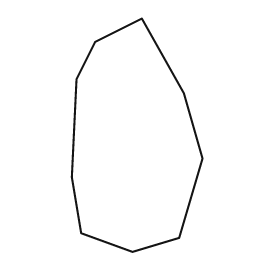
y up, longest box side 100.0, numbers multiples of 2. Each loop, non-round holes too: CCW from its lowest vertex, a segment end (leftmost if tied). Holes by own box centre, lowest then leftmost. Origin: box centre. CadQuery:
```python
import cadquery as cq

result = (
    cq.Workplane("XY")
    .moveTo(-2.0, -50.0)
    .lineTo(18.0, -44.0)
    .lineTo(28.0, -10.0)
    .lineTo(20.0, 18.0)
    .lineTo(2.0, 50.0)
    .lineTo(-18.0, 40.0)
    .lineTo(-26.0, 24.0)
    .lineTo(-28.0, -18.0)
    .lineTo(-24.0, -42.0)
    .close()
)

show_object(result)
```